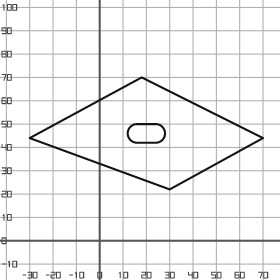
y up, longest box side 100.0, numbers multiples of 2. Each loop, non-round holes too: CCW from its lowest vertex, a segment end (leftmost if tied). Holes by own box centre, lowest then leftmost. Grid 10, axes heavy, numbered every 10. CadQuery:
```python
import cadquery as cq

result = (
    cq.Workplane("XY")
    .moveTo(30.0, 22.0)
    .lineTo(70.0, 44.0)
    .lineTo(18.0, 70.0)
    .lineTo(-30.0, 44.0)
    .close()
    .moveTo(16.0, 42.0)
    .lineTo(24.0, 42.0)
    .threePointArc((28.0, 46.0), (24.0, 50.0))
    .lineTo(16.0, 50.0)
    .threePointArc((12.0, 46.0), (16.0, 42.0))
    .close()
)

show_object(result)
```